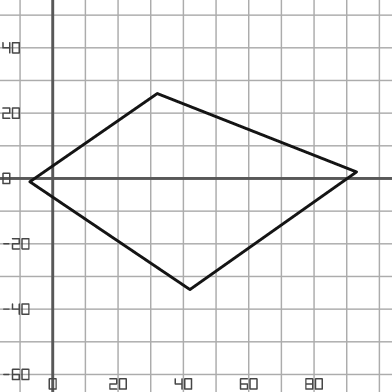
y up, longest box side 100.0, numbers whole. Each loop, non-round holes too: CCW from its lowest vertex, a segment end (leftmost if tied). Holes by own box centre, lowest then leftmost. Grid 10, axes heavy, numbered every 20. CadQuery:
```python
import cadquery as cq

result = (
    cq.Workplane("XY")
    .moveTo(42.0, -34.0)
    .lineTo(93.0, 2.0)
    .lineTo(32.0, 26.0)
    .lineTo(-7.0, -1.0)
    .close()
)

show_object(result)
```